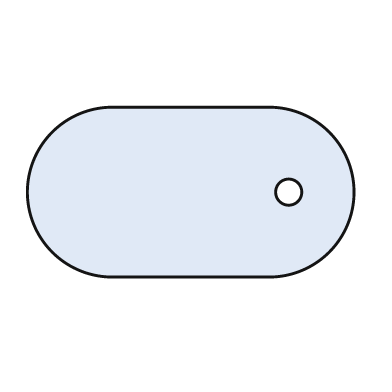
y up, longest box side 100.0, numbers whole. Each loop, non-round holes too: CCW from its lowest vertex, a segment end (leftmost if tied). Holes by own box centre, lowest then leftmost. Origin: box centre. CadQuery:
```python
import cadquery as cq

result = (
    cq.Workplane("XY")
    .moveTo(-24.0, -26.0)
    .lineTo(24.0, -26.0)
    .threePointArc((50.0, 0.0), (24.0, 26.0))
    .lineTo(-24.0, 26.0)
    .threePointArc((-50.0, 0.0), (-24.0, -26.0))
    .close()
    .moveTo(30.0, 0.0)
    .circle(4.0)
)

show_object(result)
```